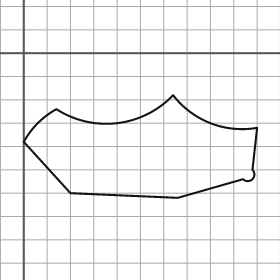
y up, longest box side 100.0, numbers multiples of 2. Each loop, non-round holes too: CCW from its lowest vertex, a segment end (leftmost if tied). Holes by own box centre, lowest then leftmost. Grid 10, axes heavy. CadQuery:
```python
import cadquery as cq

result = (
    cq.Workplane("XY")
    .moveTo(66.0, -62.0)
    .lineTo(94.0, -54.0)
    .threePointArc((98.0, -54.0), (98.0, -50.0))
    .lineTo(100.0, -32.0)
    .threePointArc((80.0, -30.0), (64.0, -18.0))
    .threePointArc((40.0, -30.0), (14.0, -24.0))
    .threePointArc((6.0, -30.0), (0.0, -38.0))
    .lineTo(20.0, -60.0)
    .close()
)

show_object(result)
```